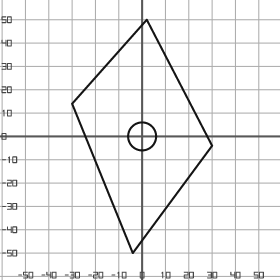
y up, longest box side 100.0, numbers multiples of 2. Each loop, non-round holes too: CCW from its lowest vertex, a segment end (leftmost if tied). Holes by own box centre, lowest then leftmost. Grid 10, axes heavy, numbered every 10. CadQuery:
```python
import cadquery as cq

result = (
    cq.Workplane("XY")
    .moveTo(-4.0, -50.0)
    .lineTo(30.0, -4.0)
    .lineTo(2.0, 50.0)
    .lineTo(-30.0, 14.0)
    .close()
    .moveTo(0.0, 0.0)
    .circle(6.0)
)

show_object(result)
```